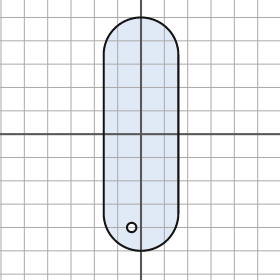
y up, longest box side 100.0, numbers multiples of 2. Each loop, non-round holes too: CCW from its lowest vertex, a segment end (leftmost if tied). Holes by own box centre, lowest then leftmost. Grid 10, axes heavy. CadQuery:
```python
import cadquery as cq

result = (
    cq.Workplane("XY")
    .moveTo(-16.0, -34.0)
    .threePointArc((0.0, -50.0), (16.0, -34.0))
    .lineTo(16.0, 34.0)
    .threePointArc((0.0, 50.0), (-16.0, 34.0))
    .close()
    .moveTo(-4.0, -40.0)
    .circle(2.0)
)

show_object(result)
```